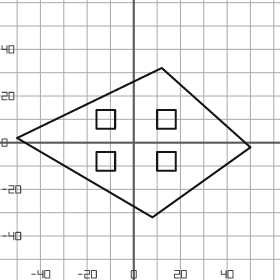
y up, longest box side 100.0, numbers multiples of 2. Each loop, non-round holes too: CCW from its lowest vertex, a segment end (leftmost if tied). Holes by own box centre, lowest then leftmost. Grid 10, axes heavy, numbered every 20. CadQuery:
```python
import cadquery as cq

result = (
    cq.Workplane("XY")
    .moveTo(8.0, -32.0)
    .lineTo(50.0, -2.0)
    .lineTo(12.0, 32.0)
    .lineTo(-50.0, 2.0)
    .close()
    .moveTo(-16.0, -12.0)
    .lineTo(-8.0, -12.0)
    .lineTo(-8.0, -4.0)
    .lineTo(-16.0, -4.0)
    .close()
    .moveTo(10.0, -12.0)
    .lineTo(18.0, -12.0)
    .lineTo(18.0, -4.0)
    .lineTo(10.0, -4.0)
    .close()
    .moveTo(-16.0, 6.0)
    .lineTo(-8.0, 6.0)
    .lineTo(-8.0, 14.0)
    .lineTo(-16.0, 14.0)
    .close()
    .moveTo(10.0, 6.0)
    .lineTo(18.0, 6.0)
    .lineTo(18.0, 14.0)
    .lineTo(10.0, 14.0)
    .close()
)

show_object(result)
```